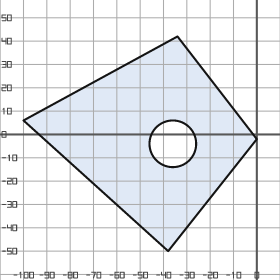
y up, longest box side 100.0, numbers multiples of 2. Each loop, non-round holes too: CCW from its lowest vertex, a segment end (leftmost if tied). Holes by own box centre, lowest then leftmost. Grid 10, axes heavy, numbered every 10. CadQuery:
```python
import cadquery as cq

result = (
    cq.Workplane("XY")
    .moveTo(-38.0, -50.0)
    .lineTo(0.0, -2.0)
    .lineTo(-34.0, 42.0)
    .lineTo(-100.0, 6.0)
    .close()
    .moveTo(-36.0, -4.0)
    .circle(10.0)
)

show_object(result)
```